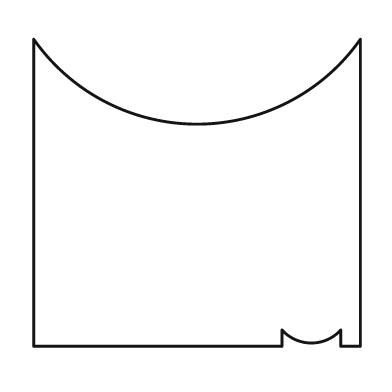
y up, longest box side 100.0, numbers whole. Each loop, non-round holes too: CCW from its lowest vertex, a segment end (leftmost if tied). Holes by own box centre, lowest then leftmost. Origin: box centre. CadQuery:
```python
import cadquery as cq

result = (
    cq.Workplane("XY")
    .moveTo(-50.0, -47.0)
    .lineTo(26.0, -47.0)
    .lineTo(26.0, -42.0)
    .threePointArc((35.0, -46.0), (44.0, -42.0))
    .lineTo(44.0, -47.0)
    .lineTo(50.0, -47.0)
    .lineTo(50.0, 47.0)
    .threePointArc((0.0, 21.0), (-50.0, 47.0))
    .close()
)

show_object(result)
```